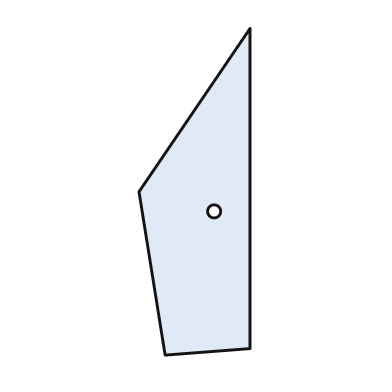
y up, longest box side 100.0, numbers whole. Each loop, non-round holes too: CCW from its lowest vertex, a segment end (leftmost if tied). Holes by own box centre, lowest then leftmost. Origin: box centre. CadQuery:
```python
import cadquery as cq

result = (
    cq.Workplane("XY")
    .moveTo(-9.0, -50.0)
    .lineTo(17.0, -48.0)
    .lineTo(17.0, 50.0)
    .lineTo(-17.0, 0.0)
    .close()
    .moveTo(6.0, -6.0)
    .circle(2.0)
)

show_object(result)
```